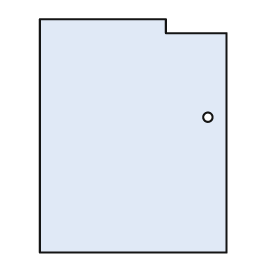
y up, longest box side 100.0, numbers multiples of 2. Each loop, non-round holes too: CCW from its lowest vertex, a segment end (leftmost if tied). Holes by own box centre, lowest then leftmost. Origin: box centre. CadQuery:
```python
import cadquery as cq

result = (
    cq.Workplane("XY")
    .moveTo(-40.0, -50.0)
    .lineTo(40.0, -50.0)
    .lineTo(40.0, 44.0)
    .lineTo(14.0, 44.0)
    .lineTo(14.0, 50.0)
    .lineTo(-40.0, 50.0)
    .close()
    .moveTo(32.0, 8.0)
    .circle(2.0)
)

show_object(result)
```